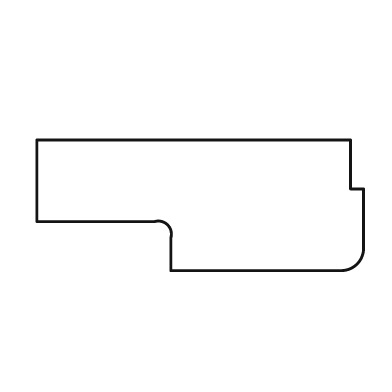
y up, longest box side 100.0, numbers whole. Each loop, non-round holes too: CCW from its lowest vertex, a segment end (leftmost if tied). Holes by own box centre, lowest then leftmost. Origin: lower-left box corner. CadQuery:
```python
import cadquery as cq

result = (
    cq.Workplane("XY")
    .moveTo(41.0, 0.0)
    .lineTo(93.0, 0.0)
    .threePointArc((98.0, 2.0), (100.0, 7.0))
    .lineTo(100.0, 25.0)
    .lineTo(96.0, 25.0)
    .lineTo(96.0, 40.0)
    .lineTo(0.0, 40.0)
    .lineTo(0.0, 15.0)
    .lineTo(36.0, 15.0)
    .threePointArc((40.0, 14.0), (41.0, 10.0))
    .close()
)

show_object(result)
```